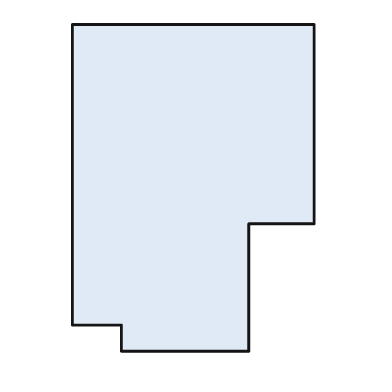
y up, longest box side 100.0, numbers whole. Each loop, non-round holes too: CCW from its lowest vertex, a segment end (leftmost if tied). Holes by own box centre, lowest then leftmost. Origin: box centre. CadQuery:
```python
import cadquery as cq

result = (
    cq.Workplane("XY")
    .moveTo(-22.0, -50.0)
    .lineTo(17.0, -50.0)
    .lineTo(17.0, -11.0)
    .lineTo(37.0, -11.0)
    .lineTo(37.0, 50.0)
    .lineTo(-37.0, 50.0)
    .lineTo(-37.0, -42.0)
    .lineTo(-22.0, -42.0)
    .close()
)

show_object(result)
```